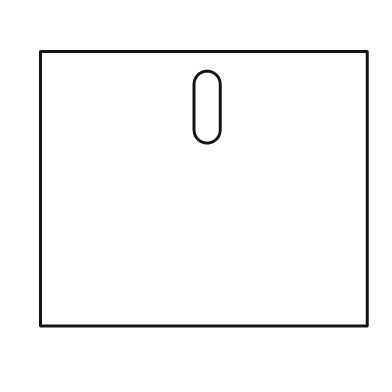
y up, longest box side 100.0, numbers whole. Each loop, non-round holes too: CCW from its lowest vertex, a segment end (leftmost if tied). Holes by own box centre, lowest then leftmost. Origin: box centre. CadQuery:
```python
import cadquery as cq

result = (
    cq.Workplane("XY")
    .moveTo(-50.0, -42.0)
    .lineTo(50.0, -42.0)
    .lineTo(50.0, 42.0)
    .lineTo(-50.0, 42.0)
    .close()
    .moveTo(-3.0, 18.0)
    .threePointArc((1.0, 14.0), (5.0, 18.0))
    .lineTo(5.0, 32.0)
    .threePointArc((1.0, 36.0), (-3.0, 32.0))
    .close()
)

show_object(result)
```